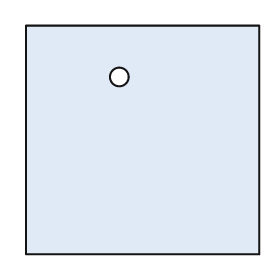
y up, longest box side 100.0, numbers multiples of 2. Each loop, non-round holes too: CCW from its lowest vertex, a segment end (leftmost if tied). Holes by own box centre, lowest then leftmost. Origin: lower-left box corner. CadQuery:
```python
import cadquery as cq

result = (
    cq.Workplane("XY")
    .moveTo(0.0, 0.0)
    .lineTo(100.0, 0.0)
    .lineTo(100.0, 98.0)
    .lineTo(0.0, 98.0)
    .close()
    .moveTo(40.0, 76.0)
    .circle(4.0)
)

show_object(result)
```